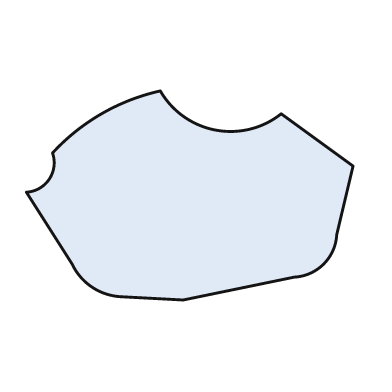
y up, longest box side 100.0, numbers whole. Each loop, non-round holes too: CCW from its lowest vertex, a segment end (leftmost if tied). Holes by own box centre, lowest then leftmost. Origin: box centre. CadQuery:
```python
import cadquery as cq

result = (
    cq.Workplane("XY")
    .moveTo(-2.0, -32.0)
    .lineTo(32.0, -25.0)
    .threePointArc((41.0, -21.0), (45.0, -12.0))
    .lineTo(50.0, 9.0)
    .lineTo(28.0, 25.0)
    .threePointArc((8.0, 20.0), (-9.0, 32.0))
    .threePointArc((-27.0, 25.0), (-42.0, 13.0))
    .threePointArc((-43.0, 5.0), (-50.0, 1.0))
    .lineTo(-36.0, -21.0)
    .threePointArc((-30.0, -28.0), (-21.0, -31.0))
    .close()
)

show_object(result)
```